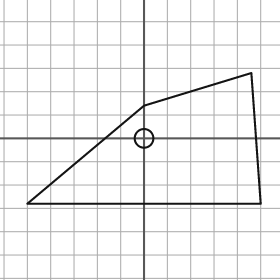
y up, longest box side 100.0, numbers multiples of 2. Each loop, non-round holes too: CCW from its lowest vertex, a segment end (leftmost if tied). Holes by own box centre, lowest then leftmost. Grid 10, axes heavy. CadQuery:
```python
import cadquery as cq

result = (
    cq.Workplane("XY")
    .moveTo(-50.0, -28.0)
    .lineTo(50.0, -28.0)
    .lineTo(46.0, 28.0)
    .lineTo(0.0, 14.0)
    .close()
    .moveTo(0.0, 0.0)
    .circle(4.0)
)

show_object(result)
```